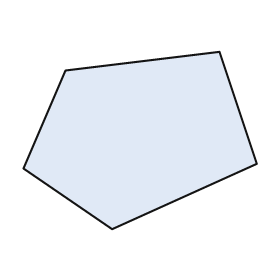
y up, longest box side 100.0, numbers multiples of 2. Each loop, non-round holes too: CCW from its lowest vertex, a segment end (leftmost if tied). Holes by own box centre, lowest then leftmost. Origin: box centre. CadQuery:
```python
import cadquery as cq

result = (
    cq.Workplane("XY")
    .moveTo(-12.0, -38.0)
    .lineTo(50.0, -10.0)
    .lineTo(34.0, 38.0)
    .lineTo(-32.0, 30.0)
    .lineTo(-50.0, -12.0)
    .close()
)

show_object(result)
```